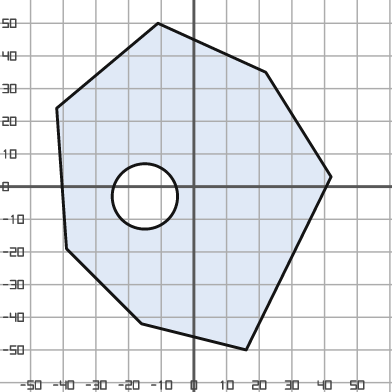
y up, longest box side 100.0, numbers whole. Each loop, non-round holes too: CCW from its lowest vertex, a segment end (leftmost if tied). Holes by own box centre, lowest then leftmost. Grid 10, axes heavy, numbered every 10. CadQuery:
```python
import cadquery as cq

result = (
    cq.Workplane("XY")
    .moveTo(16.0, -50.0)
    .lineTo(42.0, 3.0)
    .lineTo(22.0, 35.0)
    .lineTo(-11.0, 50.0)
    .lineTo(-42.0, 24.0)
    .lineTo(-39.0, -19.0)
    .lineTo(-16.0, -42.0)
    .close()
    .moveTo(-15.0, -3.0)
    .circle(10.0)
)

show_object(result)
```